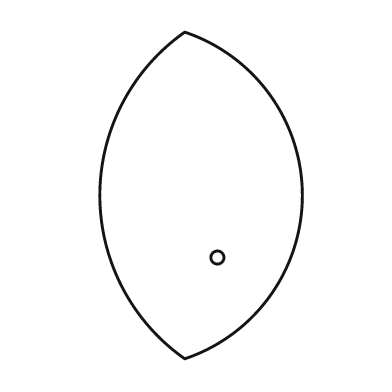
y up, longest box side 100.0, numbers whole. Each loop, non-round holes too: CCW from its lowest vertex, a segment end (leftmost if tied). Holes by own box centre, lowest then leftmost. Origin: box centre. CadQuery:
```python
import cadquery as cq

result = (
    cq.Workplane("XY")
    .moveTo(-5.0, -50.0)
    .threePointArc((31.0, 0.0), (-5.0, 50.0))
    .threePointArc((-31.0, 0.0), (-5.0, -50.0))
    .close()
    .moveTo(5.0, -19.0)
    .circle(2.0)
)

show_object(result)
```